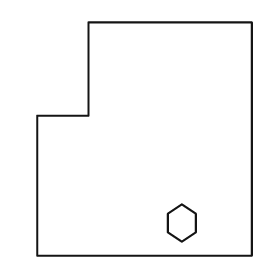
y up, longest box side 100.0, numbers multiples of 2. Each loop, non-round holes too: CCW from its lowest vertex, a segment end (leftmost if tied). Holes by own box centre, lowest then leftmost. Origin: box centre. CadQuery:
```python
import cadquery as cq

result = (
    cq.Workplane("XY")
    .moveTo(-46.0, -50.0)
    .lineTo(46.0, -50.0)
    .lineTo(46.0, 50.0)
    .lineTo(-24.0, 50.0)
    .lineTo(-24.0, 10.0)
    .lineTo(-46.0, 10.0)
    .close()
    .moveTo(16.0, -44.0)
    .lineTo(22.0, -40.0)
    .lineTo(22.0, -32.0)
    .lineTo(16.0, -28.0)
    .lineTo(10.0, -32.0)
    .lineTo(10.0, -40.0)
    .close()
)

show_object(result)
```